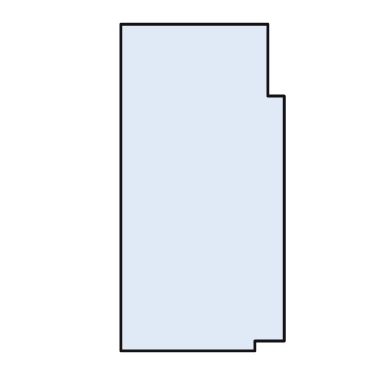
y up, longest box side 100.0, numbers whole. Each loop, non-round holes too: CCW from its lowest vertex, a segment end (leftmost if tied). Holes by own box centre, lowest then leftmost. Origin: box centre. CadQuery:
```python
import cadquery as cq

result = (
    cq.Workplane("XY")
    .moveTo(-25.0, -50.0)
    .lineTo(16.0, -50.0)
    .lineTo(16.0, -47.0)
    .lineTo(25.0, -47.0)
    .lineTo(25.0, 28.0)
    .lineTo(20.0, 28.0)
    .lineTo(20.0, 50.0)
    .lineTo(-25.0, 50.0)
    .close()
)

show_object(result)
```